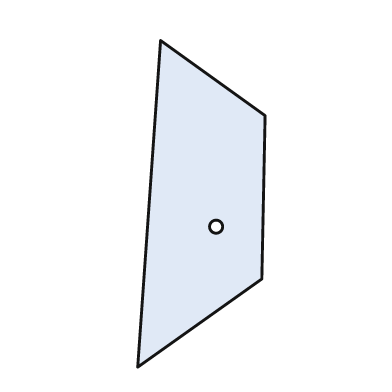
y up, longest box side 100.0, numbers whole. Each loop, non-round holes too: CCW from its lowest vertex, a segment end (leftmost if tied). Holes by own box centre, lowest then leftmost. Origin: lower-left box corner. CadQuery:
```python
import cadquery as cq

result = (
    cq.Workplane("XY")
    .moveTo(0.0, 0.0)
    .lineTo(38.0, 27.0)
    .lineTo(39.0, 77.0)
    .lineTo(7.0, 100.0)
    .close()
    .moveTo(24.0, 43.0)
    .circle(2.0)
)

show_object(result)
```